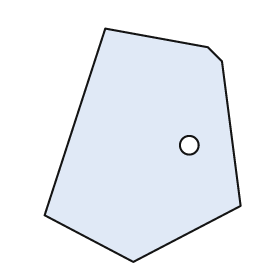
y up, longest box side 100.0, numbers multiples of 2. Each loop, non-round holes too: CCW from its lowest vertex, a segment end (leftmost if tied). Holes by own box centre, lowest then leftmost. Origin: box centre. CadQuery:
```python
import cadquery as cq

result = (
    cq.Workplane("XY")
    .moveTo(-4.0, -50.0)
    .lineTo(42.0, -26.0)
    .lineTo(34.0, 36.0)
    .lineTo(28.0, 42.0)
    .lineTo(-16.0, 50.0)
    .lineTo(-42.0, -30.0)
    .close()
    .moveTo(20.0, 0.0)
    .circle(4.0)
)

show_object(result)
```